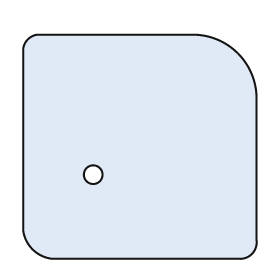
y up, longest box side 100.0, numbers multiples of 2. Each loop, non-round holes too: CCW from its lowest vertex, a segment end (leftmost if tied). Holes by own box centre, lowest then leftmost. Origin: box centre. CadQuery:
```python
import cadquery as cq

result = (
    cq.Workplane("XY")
    .moveTo(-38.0, -48.0)
    .lineTo(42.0, -48.0)
    .threePointArc((48.0, -46.0), (50.0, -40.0))
    .lineTo(50.0, 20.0)
    .threePointArc((42.0, 40.0), (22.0, 48.0))
    .lineTo(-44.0, 48.0)
    .threePointArc((-48.0, 46.0), (-50.0, 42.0))
    .lineTo(-50.0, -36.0)
    .threePointArc((-46.0, -44.0), (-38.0, -48.0))
    .close()
    .moveTo(-20.0, -12.0)
    .circle(4.0)
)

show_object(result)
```